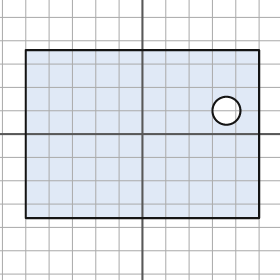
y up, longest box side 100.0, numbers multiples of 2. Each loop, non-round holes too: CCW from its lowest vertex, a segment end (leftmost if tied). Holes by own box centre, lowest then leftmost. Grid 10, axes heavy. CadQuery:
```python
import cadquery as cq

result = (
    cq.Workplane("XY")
    .moveTo(-50.0, -36.0)
    .lineTo(50.0, -36.0)
    .lineTo(50.0, 36.0)
    .lineTo(-50.0, 36.0)
    .close()
    .moveTo(36.0, 10.0)
    .circle(6.0)
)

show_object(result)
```